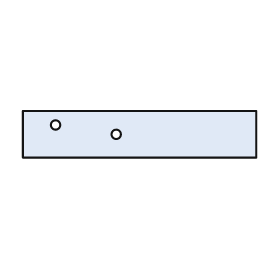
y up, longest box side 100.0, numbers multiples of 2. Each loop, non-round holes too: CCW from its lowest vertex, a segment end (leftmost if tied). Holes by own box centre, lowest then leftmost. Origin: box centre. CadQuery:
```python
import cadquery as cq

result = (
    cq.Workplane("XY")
    .moveTo(-50.0, -10.0)
    .lineTo(50.0, -10.0)
    .lineTo(50.0, 10.0)
    .lineTo(-50.0, 10.0)
    .close()
    .moveTo(-10.0, 0.0)
    .circle(2.0)
    .moveTo(-36.0, 4.0)
    .circle(2.0)
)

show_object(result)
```